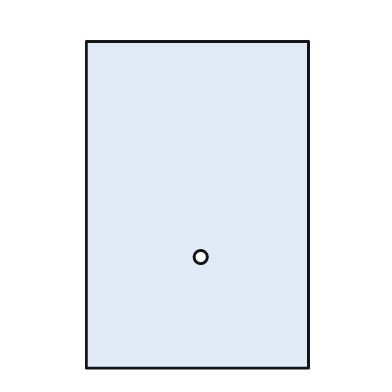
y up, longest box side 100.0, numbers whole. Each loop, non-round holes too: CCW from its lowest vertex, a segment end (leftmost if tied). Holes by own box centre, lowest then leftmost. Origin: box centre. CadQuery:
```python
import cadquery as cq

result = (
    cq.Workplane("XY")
    .moveTo(-34.0, -50.0)
    .lineTo(34.0, -50.0)
    .lineTo(34.0, 50.0)
    .lineTo(-34.0, 50.0)
    .close()
    .moveTo(1.0, -16.0)
    .circle(2.0)
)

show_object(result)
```